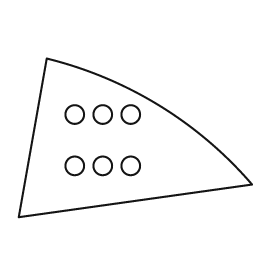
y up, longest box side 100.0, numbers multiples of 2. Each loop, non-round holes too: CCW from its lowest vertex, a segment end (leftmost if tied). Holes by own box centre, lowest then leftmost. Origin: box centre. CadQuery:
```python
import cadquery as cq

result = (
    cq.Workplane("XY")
    .moveTo(-50.0, -34.0)
    .lineTo(50.0, -20.0)
    .threePointArc((10.0, 14.0), (-38.0, 34.0))
    .close()
    .moveTo(-26.0, -12.0)
    .circle(4.0)
    .moveTo(-14.0, -12.0)
    .circle(4.0)
    .moveTo(-2.0, -12.0)
    .circle(4.0)
    .moveTo(-26.0, 10.0)
    .circle(4.0)
    .moveTo(-14.0, 10.0)
    .circle(4.0)
    .moveTo(-2.0, 10.0)
    .circle(4.0)
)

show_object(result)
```